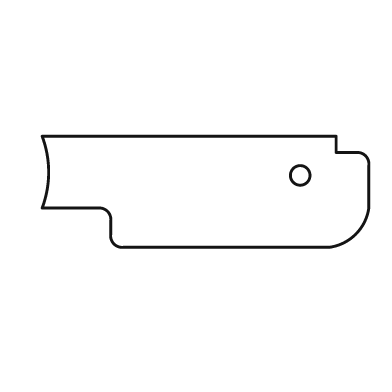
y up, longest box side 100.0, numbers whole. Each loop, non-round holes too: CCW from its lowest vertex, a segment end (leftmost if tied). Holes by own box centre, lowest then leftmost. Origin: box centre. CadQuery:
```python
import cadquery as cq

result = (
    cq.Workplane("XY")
    .moveTo(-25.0, -17.0)
    .lineTo(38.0, -17.0)
    .threePointArc((46.0, -13.0), (50.0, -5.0))
    .lineTo(50.0, 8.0)
    .threePointArc((49.0, 11.0), (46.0, 12.0))
    .lineTo(40.0, 12.0)
    .lineTo(40.0, 17.0)
    .lineTo(-50.0, 17.0)
    .threePointArc((-48.0, 6.0), (-50.0, -5.0))
    .lineTo(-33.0, -5.0)
    .threePointArc((-30.0, -6.0), (-29.0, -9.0))
    .lineTo(-29.0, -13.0)
    .threePointArc((-28.0, -16.0), (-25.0, -17.0))
    .close()
    .moveTo(29.0, 5.0)
    .circle(3.0)
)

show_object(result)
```